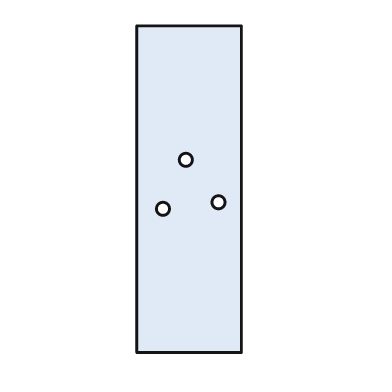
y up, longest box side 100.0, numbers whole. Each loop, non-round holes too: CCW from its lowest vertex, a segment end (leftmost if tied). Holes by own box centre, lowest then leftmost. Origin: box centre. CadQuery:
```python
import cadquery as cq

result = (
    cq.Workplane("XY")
    .moveTo(-16.0, -50.0)
    .lineTo(16.0, -50.0)
    .lineTo(16.0, 50.0)
    .lineTo(-16.0, 50.0)
    .close()
    .moveTo(-8.0, -6.0)
    .circle(2.0)
    .moveTo(9.0, -4.0)
    .circle(2.0)
    .moveTo(-1.0, 9.0)
    .circle(2.0)
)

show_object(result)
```